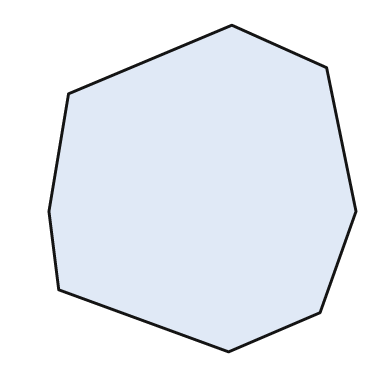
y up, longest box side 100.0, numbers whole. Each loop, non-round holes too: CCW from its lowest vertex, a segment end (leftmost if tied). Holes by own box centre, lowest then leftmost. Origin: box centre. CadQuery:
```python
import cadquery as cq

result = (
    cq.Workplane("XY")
    .moveTo(8.0, -50.0)
    .lineTo(36.0, -38.0)
    .lineTo(47.0, -7.0)
    .lineTo(38.0, 37.0)
    .lineTo(9.0, 50.0)
    .lineTo(-41.0, 29.0)
    .lineTo(-47.0, -7.0)
    .lineTo(-44.0, -31.0)
    .close()
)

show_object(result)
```